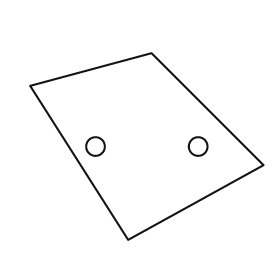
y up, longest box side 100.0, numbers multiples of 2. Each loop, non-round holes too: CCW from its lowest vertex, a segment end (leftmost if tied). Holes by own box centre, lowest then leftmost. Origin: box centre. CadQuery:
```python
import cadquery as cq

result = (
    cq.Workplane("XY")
    .moveTo(-8.0, -40.0)
    .lineTo(50.0, -8.0)
    .lineTo(2.0, 40.0)
    .lineTo(-50.0, 26.0)
    .close()
    .moveTo(-22.0, 0.0)
    .circle(4.0)
    .moveTo(22.0, 0.0)
    .circle(4.0)
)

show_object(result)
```